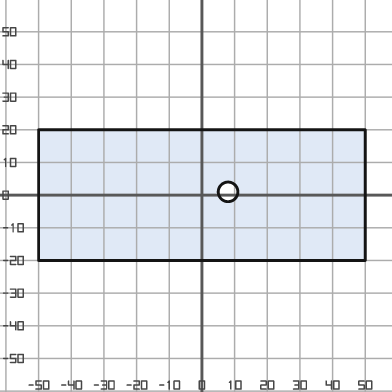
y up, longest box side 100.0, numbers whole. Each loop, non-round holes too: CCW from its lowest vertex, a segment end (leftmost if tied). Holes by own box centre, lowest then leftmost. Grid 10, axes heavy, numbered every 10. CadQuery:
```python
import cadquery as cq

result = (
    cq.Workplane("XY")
    .moveTo(-50.0, -20.0)
    .lineTo(50.0, -20.0)
    .lineTo(50.0, 20.0)
    .lineTo(-50.0, 20.0)
    .close()
    .moveTo(8.0, 1.0)
    .circle(3.0)
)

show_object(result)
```